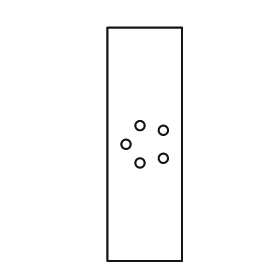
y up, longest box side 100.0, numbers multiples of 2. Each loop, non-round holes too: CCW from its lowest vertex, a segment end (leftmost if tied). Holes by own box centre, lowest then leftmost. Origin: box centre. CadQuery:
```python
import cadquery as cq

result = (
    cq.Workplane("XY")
    .moveTo(-16.0, -50.0)
    .lineTo(16.0, -50.0)
    .lineTo(16.0, 50.0)
    .lineTo(-16.0, 50.0)
    .close()
    .moveTo(-2.0, -8.0)
    .circle(2.0)
    .moveTo(8.0, -6.0)
    .circle(2.0)
    .moveTo(-8.0, 0.0)
    .circle(2.0)
    .moveTo(8.0, 6.0)
    .circle(2.0)
    .moveTo(-2.0, 8.0)
    .circle(2.0)
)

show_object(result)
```